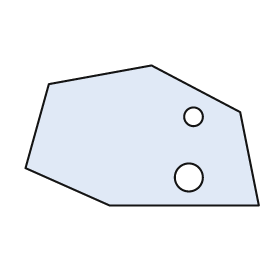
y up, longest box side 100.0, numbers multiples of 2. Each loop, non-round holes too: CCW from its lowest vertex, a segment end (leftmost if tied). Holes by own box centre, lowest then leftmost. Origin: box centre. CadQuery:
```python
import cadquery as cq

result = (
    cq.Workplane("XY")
    .moveTo(-14.0, -30.0)
    .lineTo(50.0, -30.0)
    .lineTo(42.0, 10.0)
    .lineTo(4.0, 30.0)
    .lineTo(-40.0, 22.0)
    .lineTo(-50.0, -14.0)
    .close()
    .moveTo(20.0, -18.0)
    .circle(6.0)
    .moveTo(22.0, 8.0)
    .circle(4.0)
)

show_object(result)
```